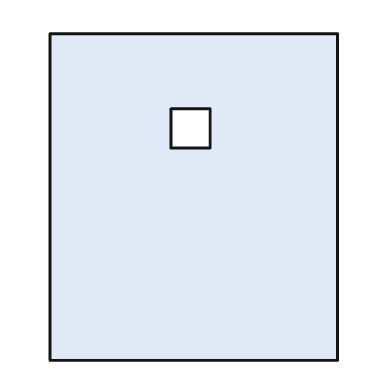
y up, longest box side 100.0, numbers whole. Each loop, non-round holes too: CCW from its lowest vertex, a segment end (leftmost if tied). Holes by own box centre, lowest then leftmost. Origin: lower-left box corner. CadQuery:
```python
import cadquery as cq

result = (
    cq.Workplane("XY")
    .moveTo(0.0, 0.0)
    .lineTo(88.0, 0.0)
    .lineTo(88.0, 100.0)
    .lineTo(0.0, 100.0)
    .close()
    .moveTo(37.0, 65.0)
    .lineTo(49.0, 65.0)
    .lineTo(49.0, 77.0)
    .lineTo(37.0, 77.0)
    .close()
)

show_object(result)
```